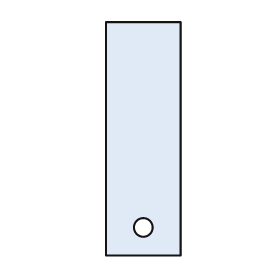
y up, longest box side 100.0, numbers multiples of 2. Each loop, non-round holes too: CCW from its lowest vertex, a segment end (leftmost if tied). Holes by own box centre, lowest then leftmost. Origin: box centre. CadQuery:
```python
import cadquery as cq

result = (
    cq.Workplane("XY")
    .moveTo(-16.0, -50.0)
    .lineTo(16.0, -50.0)
    .lineTo(16.0, 50.0)
    .lineTo(-16.0, 50.0)
    .close()
    .moveTo(0.0, -38.0)
    .circle(4.0)
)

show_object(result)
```